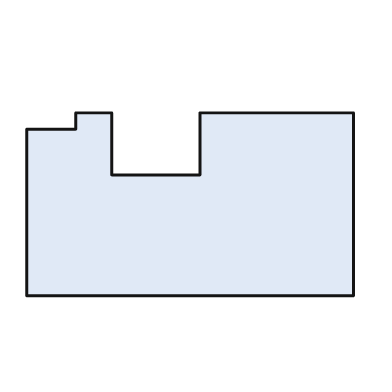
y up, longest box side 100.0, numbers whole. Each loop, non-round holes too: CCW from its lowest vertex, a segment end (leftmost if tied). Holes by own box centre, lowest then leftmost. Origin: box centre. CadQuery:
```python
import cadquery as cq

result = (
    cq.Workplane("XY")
    .moveTo(-50.0, -28.0)
    .lineTo(50.0, -28.0)
    .lineTo(50.0, 28.0)
    .lineTo(3.0, 28.0)
    .lineTo(3.0, 9.0)
    .lineTo(-24.0, 9.0)
    .lineTo(-24.0, 28.0)
    .lineTo(-35.0, 28.0)
    .lineTo(-35.0, 23.0)
    .lineTo(-50.0, 23.0)
    .close()
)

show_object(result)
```